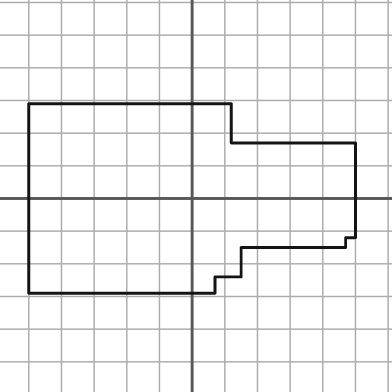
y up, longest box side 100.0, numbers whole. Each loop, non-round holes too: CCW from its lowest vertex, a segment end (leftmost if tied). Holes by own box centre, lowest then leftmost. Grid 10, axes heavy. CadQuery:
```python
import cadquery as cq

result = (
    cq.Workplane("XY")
    .moveTo(-50.0, -29.0)
    .lineTo(7.0, -29.0)
    .lineTo(7.0, -24.0)
    .lineTo(15.0, -24.0)
    .lineTo(15.0, -15.0)
    .lineTo(47.0, -15.0)
    .lineTo(47.0, -12.0)
    .lineTo(50.0, -12.0)
    .lineTo(50.0, 17.0)
    .lineTo(12.0, 17.0)
    .lineTo(12.0, 29.0)
    .lineTo(-50.0, 29.0)
    .close()
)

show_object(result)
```